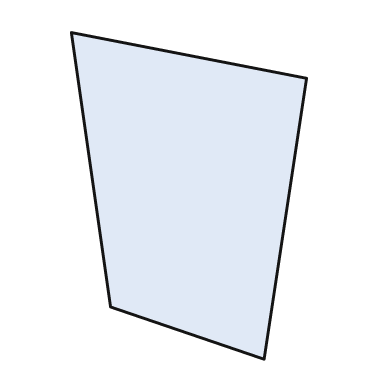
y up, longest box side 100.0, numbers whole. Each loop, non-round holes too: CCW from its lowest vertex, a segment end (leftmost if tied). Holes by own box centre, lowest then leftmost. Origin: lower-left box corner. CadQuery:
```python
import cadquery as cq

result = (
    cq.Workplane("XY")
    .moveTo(59.0, 0.0)
    .lineTo(72.0, 86.0)
    .lineTo(0.0, 100.0)
    .lineTo(12.0, 16.0)
    .close()
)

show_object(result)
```